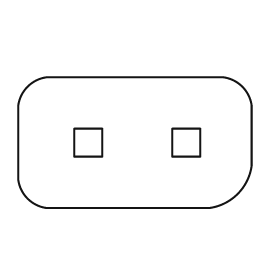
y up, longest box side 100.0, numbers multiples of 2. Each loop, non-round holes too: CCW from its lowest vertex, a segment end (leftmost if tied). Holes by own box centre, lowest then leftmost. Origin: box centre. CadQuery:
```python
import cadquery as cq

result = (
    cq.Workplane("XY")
    .moveTo(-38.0, -28.0)
    .lineTo(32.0, -28.0)
    .threePointArc((44.0, -22.0), (50.0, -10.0))
    .lineTo(50.0, 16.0)
    .threePointArc((46.0, 24.0), (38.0, 28.0))
    .lineTo(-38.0, 28.0)
    .threePointArc((-46.0, 24.0), (-50.0, 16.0))
    .lineTo(-50.0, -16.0)
    .threePointArc((-46.0, -24.0), (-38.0, -28.0))
    .close()
    .moveTo(-26.0, -6.0)
    .lineTo(-14.0, -6.0)
    .lineTo(-14.0, 6.0)
    .lineTo(-26.0, 6.0)
    .close()
    .moveTo(16.0, -6.0)
    .lineTo(28.0, -6.0)
    .lineTo(28.0, 6.0)
    .lineTo(16.0, 6.0)
    .close()
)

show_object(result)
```